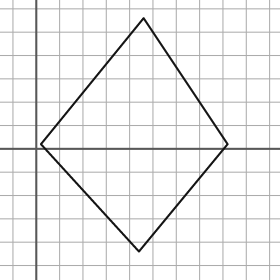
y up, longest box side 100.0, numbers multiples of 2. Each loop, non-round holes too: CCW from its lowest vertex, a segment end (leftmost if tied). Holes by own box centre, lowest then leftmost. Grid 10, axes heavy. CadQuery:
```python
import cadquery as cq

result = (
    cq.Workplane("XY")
    .moveTo(44.0, -44.0)
    .lineTo(82.0, 2.0)
    .lineTo(46.0, 56.0)
    .lineTo(2.0, 2.0)
    .close()
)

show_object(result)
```